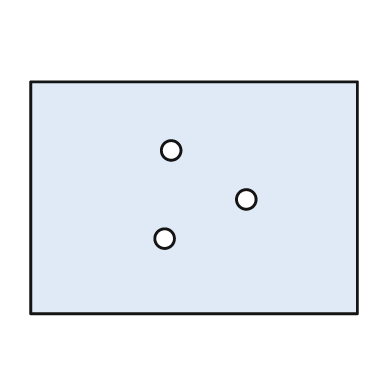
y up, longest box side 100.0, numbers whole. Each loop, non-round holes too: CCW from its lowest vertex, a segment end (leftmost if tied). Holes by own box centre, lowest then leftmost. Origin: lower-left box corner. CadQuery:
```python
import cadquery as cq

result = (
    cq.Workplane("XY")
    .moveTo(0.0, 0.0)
    .lineTo(100.0, 0.0)
    .lineTo(100.0, 71.0)
    .lineTo(0.0, 71.0)
    .close()
    .moveTo(41.0, 23.0)
    .circle(3.0)
    .moveTo(66.0, 35.0)
    .circle(3.0)
    .moveTo(43.0, 50.0)
    .circle(3.0)
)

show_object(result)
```